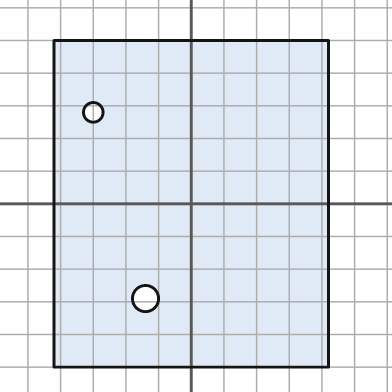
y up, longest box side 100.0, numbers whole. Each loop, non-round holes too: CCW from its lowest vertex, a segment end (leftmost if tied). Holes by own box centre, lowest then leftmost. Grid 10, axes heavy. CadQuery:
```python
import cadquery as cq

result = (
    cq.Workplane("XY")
    .moveTo(-42.0, -50.0)
    .lineTo(42.0, -50.0)
    .lineTo(42.0, 50.0)
    .lineTo(-42.0, 50.0)
    .close()
    .moveTo(-14.0, -29.0)
    .circle(4.0)
    .moveTo(-30.0, 28.0)
    .circle(3.0)
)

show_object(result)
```